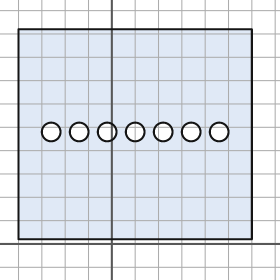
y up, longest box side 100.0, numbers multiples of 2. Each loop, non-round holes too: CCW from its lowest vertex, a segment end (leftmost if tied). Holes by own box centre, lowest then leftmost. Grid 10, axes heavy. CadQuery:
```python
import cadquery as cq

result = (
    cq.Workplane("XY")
    .moveTo(-40.0, 2.0)
    .lineTo(60.0, 2.0)
    .lineTo(60.0, 92.0)
    .lineTo(-40.0, 92.0)
    .close()
    .moveTo(-26.0, 48.0)
    .circle(4.0)
    .moveTo(-14.0, 48.0)
    .circle(4.0)
    .moveTo(-2.0, 48.0)
    .circle(4.0)
    .moveTo(10.0, 48.0)
    .circle(4.0)
    .moveTo(22.0, 48.0)
    .circle(4.0)
    .moveTo(34.0, 48.0)
    .circle(4.0)
    .moveTo(46.0, 48.0)
    .circle(4.0)
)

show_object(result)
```